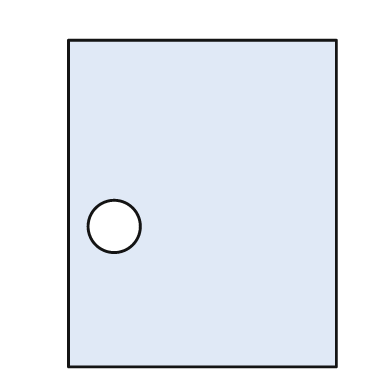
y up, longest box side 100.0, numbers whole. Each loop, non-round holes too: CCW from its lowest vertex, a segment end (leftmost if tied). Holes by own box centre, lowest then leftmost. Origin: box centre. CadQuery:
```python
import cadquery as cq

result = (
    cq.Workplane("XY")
    .moveTo(-41.0, -50.0)
    .lineTo(41.0, -50.0)
    .lineTo(41.0, 50.0)
    .lineTo(-41.0, 50.0)
    .close()
    .moveTo(-27.0, -7.0)
    .circle(8.0)
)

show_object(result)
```